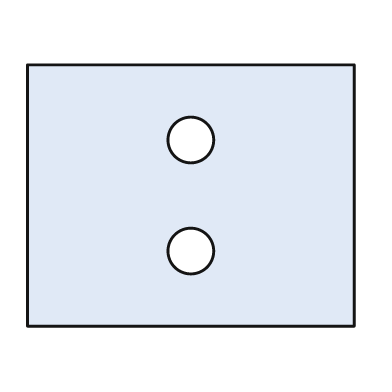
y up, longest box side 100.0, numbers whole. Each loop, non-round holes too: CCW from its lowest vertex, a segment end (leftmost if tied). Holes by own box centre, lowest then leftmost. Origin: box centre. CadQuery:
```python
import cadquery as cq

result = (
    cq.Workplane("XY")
    .moveTo(-50.0, -40.0)
    .lineTo(50.0, -40.0)
    .lineTo(50.0, 40.0)
    .lineTo(-50.0, 40.0)
    .close()
    .moveTo(0.0, -17.0)
    .circle(7.0)
    .moveTo(0.0, 17.0)
    .circle(7.0)
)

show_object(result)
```